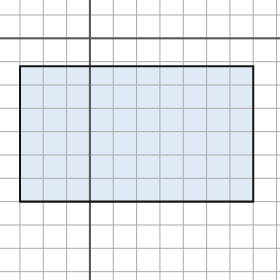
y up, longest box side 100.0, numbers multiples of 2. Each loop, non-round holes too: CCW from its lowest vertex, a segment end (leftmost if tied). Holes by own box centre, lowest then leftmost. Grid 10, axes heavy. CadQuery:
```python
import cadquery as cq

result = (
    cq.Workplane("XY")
    .moveTo(-30.0, -70.0)
    .lineTo(70.0, -70.0)
    .lineTo(70.0, -12.0)
    .lineTo(-30.0, -12.0)
    .close()
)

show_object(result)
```